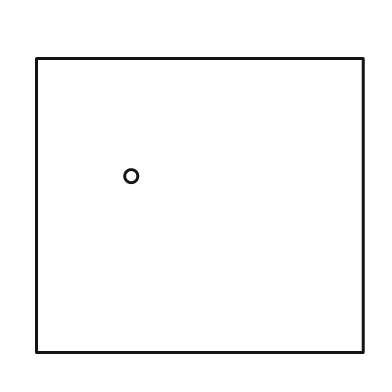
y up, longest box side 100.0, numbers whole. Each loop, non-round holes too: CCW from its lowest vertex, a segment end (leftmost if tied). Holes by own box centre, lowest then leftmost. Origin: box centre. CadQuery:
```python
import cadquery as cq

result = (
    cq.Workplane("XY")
    .moveTo(-50.0, -45.0)
    .lineTo(50.0, -45.0)
    .lineTo(50.0, 45.0)
    .lineTo(-50.0, 45.0)
    .close()
    .moveTo(-21.0, 9.0)
    .circle(2.0)
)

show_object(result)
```